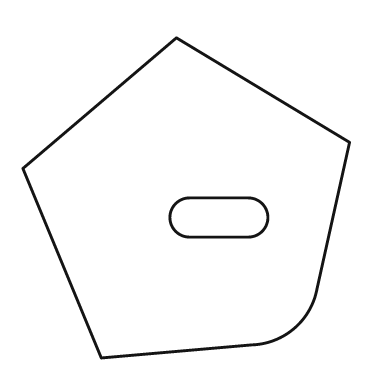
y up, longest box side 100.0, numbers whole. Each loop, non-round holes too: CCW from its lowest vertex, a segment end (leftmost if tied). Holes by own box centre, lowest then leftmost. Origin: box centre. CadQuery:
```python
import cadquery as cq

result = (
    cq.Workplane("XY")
    .moveTo(-26.0, -49.0)
    .lineTo(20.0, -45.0)
    .threePointArc((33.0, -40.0), (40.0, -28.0))
    .lineTo(50.0, 17.0)
    .lineTo(-3.0, 49.0)
    .lineTo(-50.0, 9.0)
    .close()
    .moveTo(1.0, -12.0)
    .lineTo(19.0, -12.0)
    .threePointArc((25.0, -6.0), (19.0, 0.0))
    .lineTo(1.0, 0.0)
    .threePointArc((-5.0, -6.0), (1.0, -12.0))
    .close()
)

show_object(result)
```